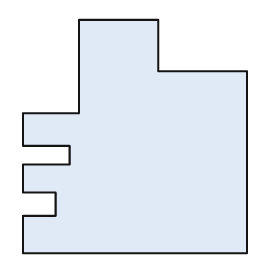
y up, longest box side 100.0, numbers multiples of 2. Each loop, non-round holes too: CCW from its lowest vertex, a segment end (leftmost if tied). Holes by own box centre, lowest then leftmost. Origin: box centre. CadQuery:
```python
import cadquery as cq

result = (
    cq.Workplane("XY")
    .moveTo(-48.0, -50.0)
    .lineTo(48.0, -50.0)
    .lineTo(48.0, 28.0)
    .lineTo(10.0, 28.0)
    .lineTo(10.0, 50.0)
    .lineTo(-24.0, 50.0)
    .lineTo(-24.0, 10.0)
    .lineTo(-48.0, 10.0)
    .lineTo(-48.0, -4.0)
    .lineTo(-28.0, -4.0)
    .lineTo(-28.0, -12.0)
    .lineTo(-48.0, -12.0)
    .lineTo(-48.0, -24.0)
    .lineTo(-34.0, -24.0)
    .lineTo(-34.0, -34.0)
    .lineTo(-48.0, -34.0)
    .close()
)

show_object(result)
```